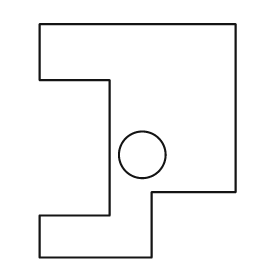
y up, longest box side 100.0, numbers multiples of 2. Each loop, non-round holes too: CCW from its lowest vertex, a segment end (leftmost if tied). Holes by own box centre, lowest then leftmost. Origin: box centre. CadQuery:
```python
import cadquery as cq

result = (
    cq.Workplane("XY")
    .moveTo(-42.0, -50.0)
    .lineTo(6.0, -50.0)
    .lineTo(6.0, -22.0)
    .lineTo(42.0, -22.0)
    .lineTo(42.0, 50.0)
    .lineTo(-42.0, 50.0)
    .lineTo(-42.0, 26.0)
    .lineTo(-12.0, 26.0)
    .lineTo(-12.0, -32.0)
    .lineTo(-42.0, -32.0)
    .close()
    .moveTo(2.0, -6.0)
    .circle(10.0)
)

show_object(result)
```